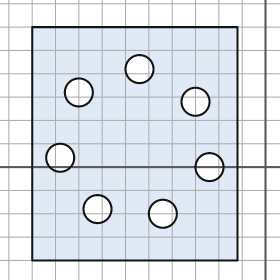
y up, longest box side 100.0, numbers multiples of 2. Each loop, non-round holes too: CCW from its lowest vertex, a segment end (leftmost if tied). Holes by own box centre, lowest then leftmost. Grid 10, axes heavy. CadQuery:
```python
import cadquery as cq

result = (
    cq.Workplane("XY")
    .moveTo(-100.0, -40.0)
    .lineTo(-12.0, -40.0)
    .lineTo(-12.0, 60.0)
    .lineTo(-100.0, 60.0)
    .close()
    .moveTo(-44.0, -20.0)
    .circle(6.0)
    .moveTo(-72.0, -18.0)
    .circle(6.0)
    .moveTo(-24.0, 0.0)
    .circle(6.0)
    .moveTo(-88.0, 4.0)
    .circle(6.0)
    .moveTo(-30.0, 28.0)
    .circle(6.0)
    .moveTo(-80.0, 32.0)
    .circle(6.0)
    .moveTo(-54.0, 42.0)
    .circle(6.0)
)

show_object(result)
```